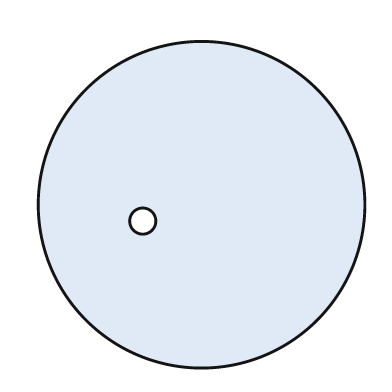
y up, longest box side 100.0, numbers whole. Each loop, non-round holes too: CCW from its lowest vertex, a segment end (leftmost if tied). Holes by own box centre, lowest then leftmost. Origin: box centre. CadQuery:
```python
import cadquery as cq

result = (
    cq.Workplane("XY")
    .moveTo(0.0, 0.0)
    .circle(50.0)
    .moveTo(-18.0, -5.0)
    .circle(4.0)
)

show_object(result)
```